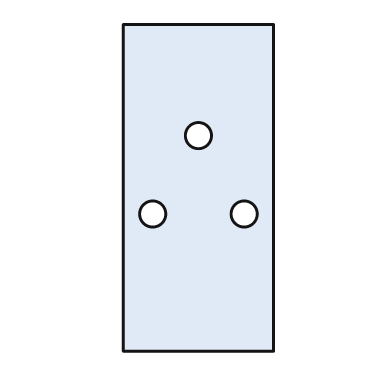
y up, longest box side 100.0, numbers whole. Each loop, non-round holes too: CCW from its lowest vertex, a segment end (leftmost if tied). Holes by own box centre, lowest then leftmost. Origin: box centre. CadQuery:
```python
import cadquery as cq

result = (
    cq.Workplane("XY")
    .moveTo(-23.0, -50.0)
    .lineTo(23.0, -50.0)
    .lineTo(23.0, 50.0)
    .lineTo(-23.0, 50.0)
    .close()
    .moveTo(-14.0, -8.0)
    .circle(4.0)
    .moveTo(14.0, -8.0)
    .circle(4.0)
    .moveTo(0.0, 16.0)
    .circle(4.0)
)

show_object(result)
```